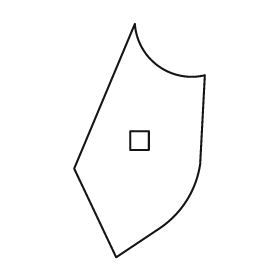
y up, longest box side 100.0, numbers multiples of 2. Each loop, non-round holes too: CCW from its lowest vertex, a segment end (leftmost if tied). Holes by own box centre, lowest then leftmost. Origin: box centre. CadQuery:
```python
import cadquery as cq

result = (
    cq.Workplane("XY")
    .moveTo(-10.0, -50.0)
    .lineTo(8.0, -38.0)
    .threePointArc((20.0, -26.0), (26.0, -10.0))
    .lineTo(28.0, 28.0)
    .threePointArc((8.0, 32.0), (-2.0, 50.0))
    .lineTo(-28.0, -12.0)
    .close()
    .moveTo(-4.0, -4.0)
    .lineTo(4.0, -4.0)
    .lineTo(4.0, 4.0)
    .lineTo(-4.0, 4.0)
    .close()
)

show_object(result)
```